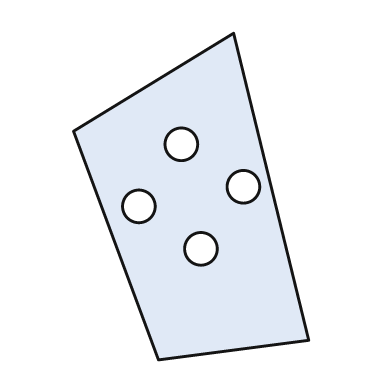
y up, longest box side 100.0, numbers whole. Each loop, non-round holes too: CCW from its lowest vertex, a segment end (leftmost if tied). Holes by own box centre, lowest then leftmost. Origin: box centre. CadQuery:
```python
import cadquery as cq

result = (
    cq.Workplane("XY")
    .moveTo(-10.0, -50.0)
    .lineTo(36.0, -44.0)
    .lineTo(13.0, 50.0)
    .lineTo(-36.0, 20.0)
    .close()
    .moveTo(3.0, -16.0)
    .circle(5.0)
    .moveTo(-16.0, -3.0)
    .circle(5.0)
    .moveTo(16.0, 3.0)
    .circle(5.0)
    .moveTo(-3.0, 16.0)
    .circle(5.0)
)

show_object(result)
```